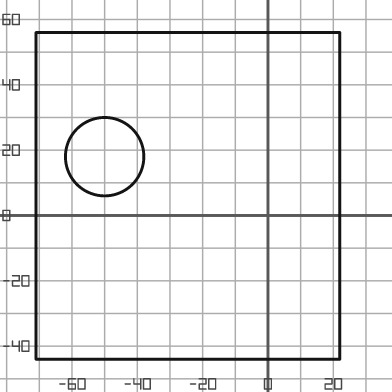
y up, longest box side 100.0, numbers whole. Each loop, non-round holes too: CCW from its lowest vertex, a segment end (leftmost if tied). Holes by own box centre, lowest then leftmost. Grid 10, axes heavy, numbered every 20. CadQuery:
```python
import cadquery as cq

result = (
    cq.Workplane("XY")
    .moveTo(-71.0, -44.0)
    .lineTo(22.0, -44.0)
    .lineTo(22.0, 56.0)
    .lineTo(-71.0, 56.0)
    .close()
    .moveTo(-50.0, 18.0)
    .circle(12.0)
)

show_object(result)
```